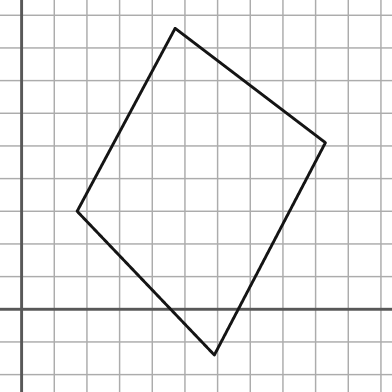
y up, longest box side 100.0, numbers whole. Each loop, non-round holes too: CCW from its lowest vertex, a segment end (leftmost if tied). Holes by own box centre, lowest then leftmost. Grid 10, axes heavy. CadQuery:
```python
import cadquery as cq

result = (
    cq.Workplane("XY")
    .moveTo(59.0, -14.0)
    .lineTo(93.0, 51.0)
    .lineTo(47.0, 86.0)
    .lineTo(17.0, 30.0)
    .close()
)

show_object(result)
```